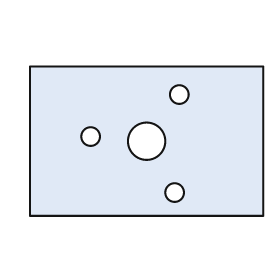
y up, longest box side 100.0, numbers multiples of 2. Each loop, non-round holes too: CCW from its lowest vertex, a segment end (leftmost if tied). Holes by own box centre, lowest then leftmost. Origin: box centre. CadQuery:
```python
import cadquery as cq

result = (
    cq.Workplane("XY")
    .moveTo(-50.0, -32.0)
    .lineTo(50.0, -32.0)
    .lineTo(50.0, 32.0)
    .lineTo(-50.0, 32.0)
    .close()
    .moveTo(12.0, -22.0)
    .circle(4.0)
    .moveTo(0.0, 0.0)
    .circle(8.0)
    .moveTo(-24.0, 2.0)
    .circle(4.0)
    .moveTo(14.0, 20.0)
    .circle(4.0)
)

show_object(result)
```